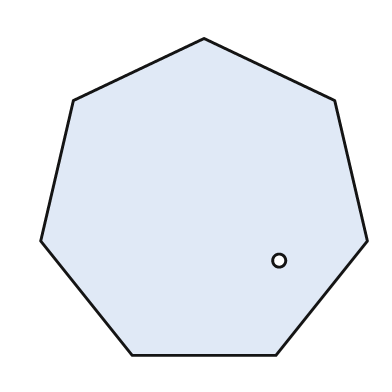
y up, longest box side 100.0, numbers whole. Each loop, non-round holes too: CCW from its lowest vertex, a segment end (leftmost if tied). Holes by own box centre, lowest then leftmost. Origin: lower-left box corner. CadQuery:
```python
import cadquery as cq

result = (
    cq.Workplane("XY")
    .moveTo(28.0, 0.0)
    .lineTo(72.0, 0.0)
    .lineTo(100.0, 35.0)
    .lineTo(90.0, 78.0)
    .lineTo(50.0, 97.0)
    .lineTo(10.0, 78.0)
    .lineTo(0.0, 35.0)
    .close()
    .moveTo(73.0, 29.0)
    .circle(2.0)
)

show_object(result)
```